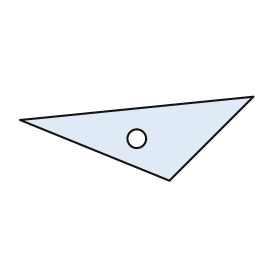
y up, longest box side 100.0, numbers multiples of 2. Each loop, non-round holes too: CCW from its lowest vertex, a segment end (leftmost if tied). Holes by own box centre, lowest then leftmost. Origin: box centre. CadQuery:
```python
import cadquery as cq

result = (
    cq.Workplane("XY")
    .moveTo(14.0, -18.0)
    .lineTo(50.0, 18.0)
    .lineTo(-50.0, 8.0)
    .close()
    .moveTo(0.0, 0.0)
    .circle(4.0)
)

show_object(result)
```